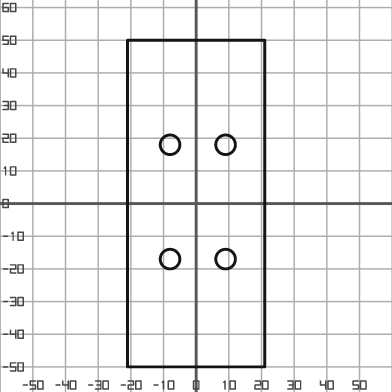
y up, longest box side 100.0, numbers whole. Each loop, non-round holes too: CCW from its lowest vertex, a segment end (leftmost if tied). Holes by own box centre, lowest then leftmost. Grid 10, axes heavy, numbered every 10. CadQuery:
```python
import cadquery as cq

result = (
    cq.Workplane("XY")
    .moveTo(-21.0, -50.0)
    .lineTo(21.0, -50.0)
    .lineTo(21.0, 50.0)
    .lineTo(-21.0, 50.0)
    .close()
    .moveTo(-8.0, -17.0)
    .circle(3.0)
    .moveTo(9.0, -17.0)
    .circle(3.0)
    .moveTo(-8.0, 18.0)
    .circle(3.0)
    .moveTo(9.0, 18.0)
    .circle(3.0)
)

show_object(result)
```